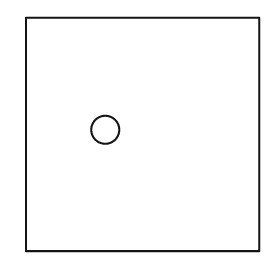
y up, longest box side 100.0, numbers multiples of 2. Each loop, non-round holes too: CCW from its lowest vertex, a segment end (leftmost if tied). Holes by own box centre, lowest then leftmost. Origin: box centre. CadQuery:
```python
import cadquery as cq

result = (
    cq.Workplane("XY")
    .moveTo(-50.0, -50.0)
    .lineTo(50.0, -50.0)
    .lineTo(50.0, 50.0)
    .lineTo(-50.0, 50.0)
    .close()
    .moveTo(-16.0, 2.0)
    .circle(6.0)
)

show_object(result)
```